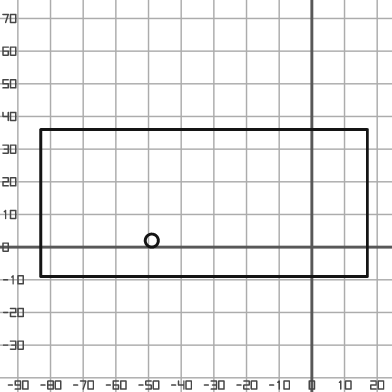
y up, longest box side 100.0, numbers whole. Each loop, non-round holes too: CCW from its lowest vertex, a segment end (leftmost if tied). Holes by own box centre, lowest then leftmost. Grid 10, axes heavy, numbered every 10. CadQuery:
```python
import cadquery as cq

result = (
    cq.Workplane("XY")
    .moveTo(-83.0, -9.0)
    .lineTo(17.0, -9.0)
    .lineTo(17.0, 36.0)
    .lineTo(-83.0, 36.0)
    .close()
    .moveTo(-49.0, 2.0)
    .circle(2.0)
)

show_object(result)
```